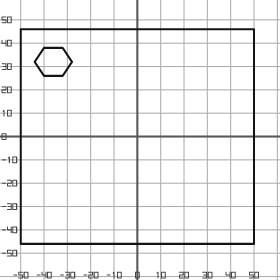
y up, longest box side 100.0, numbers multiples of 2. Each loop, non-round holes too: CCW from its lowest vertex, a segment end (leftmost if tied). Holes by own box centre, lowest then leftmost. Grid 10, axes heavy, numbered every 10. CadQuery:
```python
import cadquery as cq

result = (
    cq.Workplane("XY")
    .moveTo(-50.0, -46.0)
    .lineTo(50.0, -46.0)
    .lineTo(50.0, 46.0)
    .lineTo(-50.0, 46.0)
    .close()
    .moveTo(-40.0, 26.0)
    .lineTo(-32.0, 26.0)
    .lineTo(-28.0, 32.0)
    .lineTo(-32.0, 38.0)
    .lineTo(-40.0, 38.0)
    .lineTo(-44.0, 32.0)
    .close()
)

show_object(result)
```